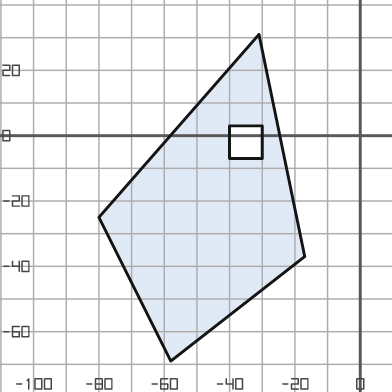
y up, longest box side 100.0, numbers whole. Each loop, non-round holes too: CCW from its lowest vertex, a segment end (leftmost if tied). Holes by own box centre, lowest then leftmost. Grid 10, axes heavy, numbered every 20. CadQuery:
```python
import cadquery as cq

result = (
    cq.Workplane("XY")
    .moveTo(-58.0, -69.0)
    .lineTo(-17.0, -37.0)
    .lineTo(-31.0, 31.0)
    .lineTo(-80.0, -25.0)
    .close()
    .moveTo(-40.0, -7.0)
    .lineTo(-30.0, -7.0)
    .lineTo(-30.0, 3.0)
    .lineTo(-40.0, 3.0)
    .close()
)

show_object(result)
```